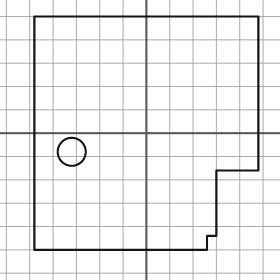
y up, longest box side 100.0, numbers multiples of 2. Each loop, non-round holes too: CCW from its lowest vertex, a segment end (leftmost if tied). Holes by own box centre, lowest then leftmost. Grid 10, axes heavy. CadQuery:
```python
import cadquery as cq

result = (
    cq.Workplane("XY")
    .moveTo(-48.0, -50.0)
    .lineTo(26.0, -50.0)
    .lineTo(26.0, -44.0)
    .lineTo(30.0, -44.0)
    .lineTo(30.0, -16.0)
    .lineTo(48.0, -16.0)
    .lineTo(48.0, 50.0)
    .lineTo(-48.0, 50.0)
    .close()
    .moveTo(-32.0, -8.0)
    .circle(6.0)
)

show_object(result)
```